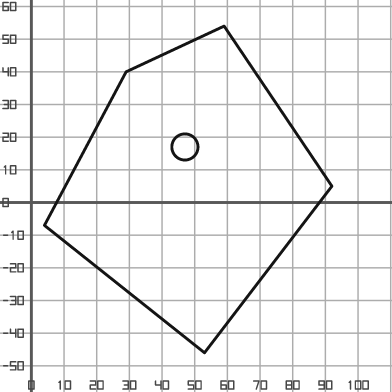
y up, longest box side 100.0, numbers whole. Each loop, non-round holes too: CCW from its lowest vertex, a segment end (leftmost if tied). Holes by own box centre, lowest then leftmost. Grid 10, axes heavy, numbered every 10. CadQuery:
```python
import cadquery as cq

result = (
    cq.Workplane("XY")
    .moveTo(53.0, -46.0)
    .lineTo(92.0, 5.0)
    .lineTo(59.0, 54.0)
    .lineTo(29.0, 40.0)
    .lineTo(4.0, -7.0)
    .close()
    .moveTo(47.0, 17.0)
    .circle(4.0)
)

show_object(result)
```